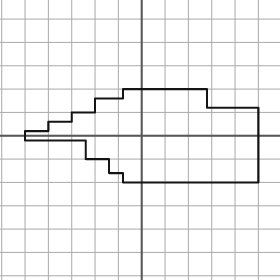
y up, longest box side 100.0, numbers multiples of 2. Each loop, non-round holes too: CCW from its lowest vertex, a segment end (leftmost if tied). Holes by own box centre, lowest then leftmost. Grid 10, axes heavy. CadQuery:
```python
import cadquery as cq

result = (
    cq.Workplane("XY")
    .moveTo(-8.0, -20.0)
    .lineTo(50.0, -20.0)
    .lineTo(50.0, 12.0)
    .lineTo(28.0, 12.0)
    .lineTo(28.0, 20.0)
    .lineTo(-8.0, 20.0)
    .lineTo(-8.0, 16.0)
    .lineTo(-20.0, 16.0)
    .lineTo(-20.0, 10.0)
    .lineTo(-30.0, 10.0)
    .lineTo(-30.0, 6.0)
    .lineTo(-40.0, 6.0)
    .lineTo(-40.0, 2.0)
    .lineTo(-50.0, 2.0)
    .lineTo(-50.0, -2.0)
    .lineTo(-24.0, -2.0)
    .lineTo(-24.0, -10.0)
    .lineTo(-14.0, -10.0)
    .lineTo(-14.0, -16.0)
    .lineTo(-8.0, -16.0)
    .close()
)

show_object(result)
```